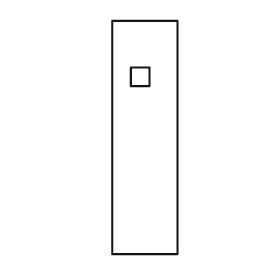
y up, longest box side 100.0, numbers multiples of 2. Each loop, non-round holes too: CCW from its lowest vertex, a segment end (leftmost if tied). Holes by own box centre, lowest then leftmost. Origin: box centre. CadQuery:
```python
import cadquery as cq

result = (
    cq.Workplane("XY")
    .moveTo(-14.0, -50.0)
    .lineTo(14.0, -50.0)
    .lineTo(14.0, 50.0)
    .lineTo(-14.0, 50.0)
    .close()
    .moveTo(-6.0, 22.0)
    .lineTo(2.0, 22.0)
    .lineTo(2.0, 30.0)
    .lineTo(-6.0, 30.0)
    .close()
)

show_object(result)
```